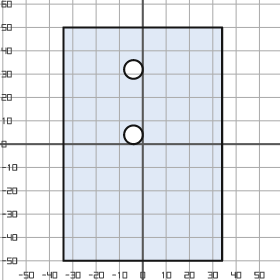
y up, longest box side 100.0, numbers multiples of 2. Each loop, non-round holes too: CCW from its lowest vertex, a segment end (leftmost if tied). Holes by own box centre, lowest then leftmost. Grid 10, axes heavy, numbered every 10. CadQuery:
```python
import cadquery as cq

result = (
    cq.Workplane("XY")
    .moveTo(-34.0, -50.0)
    .lineTo(34.0, -50.0)
    .lineTo(34.0, 50.0)
    .lineTo(-34.0, 50.0)
    .close()
    .moveTo(-4.0, 4.0)
    .circle(4.0)
    .moveTo(-4.0, 32.0)
    .circle(4.0)
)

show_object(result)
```